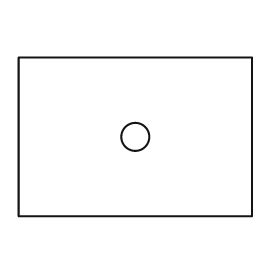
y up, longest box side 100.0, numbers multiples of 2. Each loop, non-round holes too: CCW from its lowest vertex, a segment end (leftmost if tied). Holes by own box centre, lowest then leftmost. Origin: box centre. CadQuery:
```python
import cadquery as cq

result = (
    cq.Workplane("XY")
    .moveTo(-50.0, -34.0)
    .lineTo(50.0, -34.0)
    .lineTo(50.0, 34.0)
    .lineTo(-50.0, 34.0)
    .close()
    .moveTo(0.0, 0.0)
    .circle(6.0)
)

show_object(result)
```